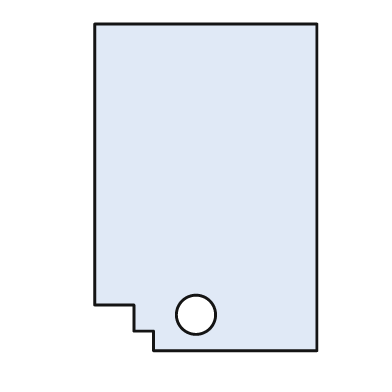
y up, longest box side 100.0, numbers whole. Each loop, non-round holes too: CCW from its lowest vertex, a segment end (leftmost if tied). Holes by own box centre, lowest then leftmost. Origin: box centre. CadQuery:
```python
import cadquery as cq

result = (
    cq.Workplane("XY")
    .moveTo(-16.0, -50.0)
    .lineTo(34.0, -50.0)
    .lineTo(34.0, 50.0)
    .lineTo(-34.0, 50.0)
    .lineTo(-34.0, -36.0)
    .lineTo(-22.0, -36.0)
    .lineTo(-22.0, -44.0)
    .lineTo(-16.0, -44.0)
    .close()
    .moveTo(-3.0, -39.0)
    .circle(6.0)
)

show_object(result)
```